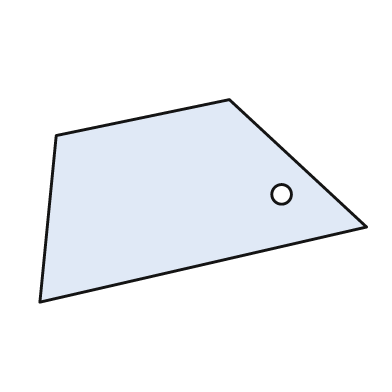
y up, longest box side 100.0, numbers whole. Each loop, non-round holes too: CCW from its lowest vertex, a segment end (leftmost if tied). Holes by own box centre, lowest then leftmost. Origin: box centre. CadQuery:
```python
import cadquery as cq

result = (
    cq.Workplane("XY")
    .moveTo(-50.0, -31.0)
    .lineTo(50.0, -8.0)
    .lineTo(8.0, 31.0)
    .lineTo(-45.0, 20.0)
    .close()
    .moveTo(24.0, 2.0)
    .circle(3.0)
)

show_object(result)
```